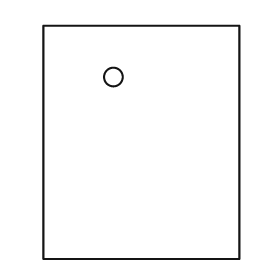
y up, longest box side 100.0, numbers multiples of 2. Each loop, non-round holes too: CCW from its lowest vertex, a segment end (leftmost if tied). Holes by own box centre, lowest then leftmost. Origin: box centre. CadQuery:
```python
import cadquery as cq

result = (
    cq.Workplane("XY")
    .moveTo(-42.0, -50.0)
    .lineTo(42.0, -50.0)
    .lineTo(42.0, 50.0)
    .lineTo(-42.0, 50.0)
    .close()
    .moveTo(-12.0, 28.0)
    .circle(4.0)
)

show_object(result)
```